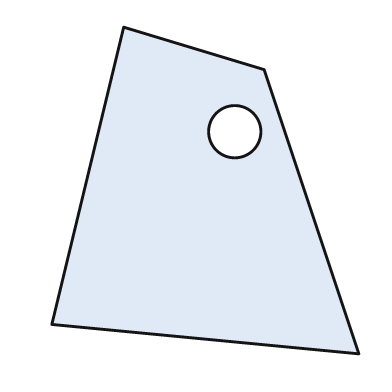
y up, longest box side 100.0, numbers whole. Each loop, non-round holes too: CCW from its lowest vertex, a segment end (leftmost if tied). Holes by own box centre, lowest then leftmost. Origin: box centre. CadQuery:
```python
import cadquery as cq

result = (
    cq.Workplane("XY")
    .moveTo(47.0, -50.0)
    .lineTo(18.0, 37.0)
    .lineTo(-25.0, 50.0)
    .lineTo(-47.0, -41.0)
    .close()
    .moveTo(9.0, 18.0)
    .circle(8.0)
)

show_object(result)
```